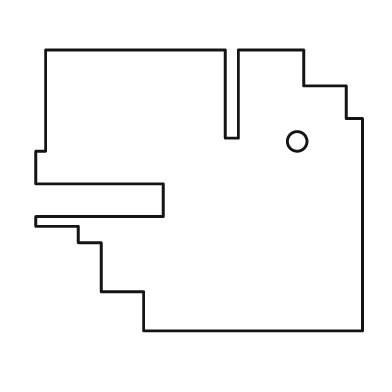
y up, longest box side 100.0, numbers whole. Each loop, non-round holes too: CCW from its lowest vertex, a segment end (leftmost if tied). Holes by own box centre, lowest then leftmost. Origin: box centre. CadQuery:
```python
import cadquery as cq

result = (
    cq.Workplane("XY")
    .moveTo(-17.0, -43.0)
    .lineTo(50.0, -43.0)
    .lineTo(50.0, 22.0)
    .lineTo(45.0, 22.0)
    .lineTo(45.0, 32.0)
    .lineTo(32.0, 32.0)
    .lineTo(32.0, 43.0)
    .lineTo(12.0, 43.0)
    .lineTo(12.0, 16.0)
    .lineTo(8.0, 16.0)
    .lineTo(8.0, 43.0)
    .lineTo(-47.0, 43.0)
    .lineTo(-47.0, 12.0)
    .lineTo(-50.0, 12.0)
    .lineTo(-50.0, 2.0)
    .lineTo(-11.0, 2.0)
    .lineTo(-11.0, -8.0)
    .lineTo(-50.0, -8.0)
    .lineTo(-50.0, -11.0)
    .lineTo(-37.0, -11.0)
    .lineTo(-37.0, -16.0)
    .lineTo(-30.0, -16.0)
    .lineTo(-30.0, -31.0)
    .lineTo(-17.0, -31.0)
    .close()
    .moveTo(30.0, 15.0)
    .circle(3.0)
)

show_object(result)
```